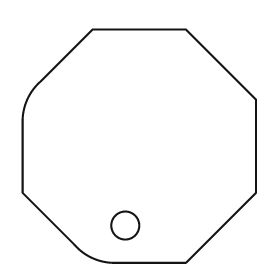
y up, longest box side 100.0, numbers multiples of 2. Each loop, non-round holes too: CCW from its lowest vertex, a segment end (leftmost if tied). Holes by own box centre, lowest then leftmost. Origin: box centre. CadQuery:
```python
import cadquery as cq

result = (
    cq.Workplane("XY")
    .moveTo(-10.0, -50.0)
    .lineTo(20.0, -50.0)
    .lineTo(50.0, -20.0)
    .lineTo(50.0, 20.0)
    .lineTo(20.0, 50.0)
    .lineTo(-20.0, 50.0)
    .lineTo(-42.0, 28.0)
    .threePointArc((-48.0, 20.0), (-50.0, 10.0))
    .lineTo(-50.0, -20.0)
    .lineTo(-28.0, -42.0)
    .threePointArc((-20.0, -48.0), (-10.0, -50.0))
    .close()
    .moveTo(-6.0, -34.0)
    .circle(6.0)
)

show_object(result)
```